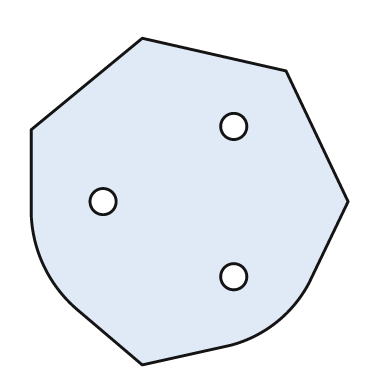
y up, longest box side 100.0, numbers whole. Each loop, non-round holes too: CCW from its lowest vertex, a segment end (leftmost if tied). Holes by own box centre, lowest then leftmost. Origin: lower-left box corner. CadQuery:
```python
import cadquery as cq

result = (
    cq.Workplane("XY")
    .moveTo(34.0, 0.0)
    .lineTo(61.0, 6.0)
    .threePointArc((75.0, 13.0), (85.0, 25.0))
    .lineTo(97.0, 50.0)
    .lineTo(78.0, 90.0)
    .lineTo(34.0, 100.0)
    .lineTo(0.0, 72.0)
    .lineTo(0.0, 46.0)
    .threePointArc((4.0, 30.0), (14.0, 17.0))
    .close()
    .moveTo(62.0, 27.0)
    .circle(4.0)
    .moveTo(22.0, 50.0)
    .circle(4.0)
    .moveTo(62.0, 73.0)
    .circle(4.0)
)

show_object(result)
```